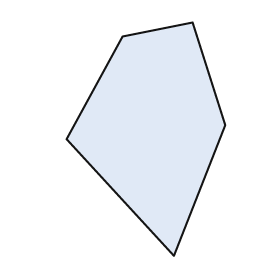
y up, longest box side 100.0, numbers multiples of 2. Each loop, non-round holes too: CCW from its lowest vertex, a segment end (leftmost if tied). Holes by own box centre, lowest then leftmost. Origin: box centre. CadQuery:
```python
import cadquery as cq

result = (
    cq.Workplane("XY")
    .moveTo(12.0, -50.0)
    .lineTo(34.0, 6.0)
    .lineTo(20.0, 50.0)
    .lineTo(-10.0, 44.0)
    .lineTo(-34.0, 0.0)
    .close()
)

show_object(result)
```